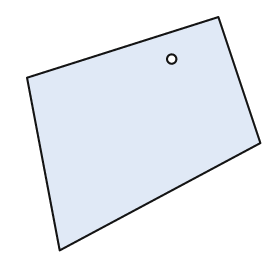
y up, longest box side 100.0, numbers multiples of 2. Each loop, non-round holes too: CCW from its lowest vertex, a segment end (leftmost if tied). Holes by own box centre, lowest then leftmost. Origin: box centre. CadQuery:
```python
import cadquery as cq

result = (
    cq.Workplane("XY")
    .moveTo(-36.0, -50.0)
    .lineTo(50.0, -4.0)
    .lineTo(32.0, 50.0)
    .lineTo(-50.0, 24.0)
    .close()
    .moveTo(12.0, 32.0)
    .circle(2.0)
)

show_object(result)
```